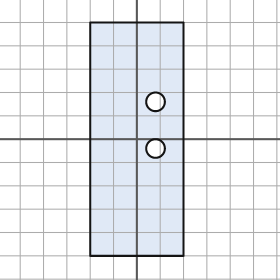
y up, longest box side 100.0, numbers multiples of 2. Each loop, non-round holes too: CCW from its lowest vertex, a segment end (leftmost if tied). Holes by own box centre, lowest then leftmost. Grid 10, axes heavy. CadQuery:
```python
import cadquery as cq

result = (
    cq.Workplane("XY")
    .moveTo(-20.0, -50.0)
    .lineTo(20.0, -50.0)
    .lineTo(20.0, 50.0)
    .lineTo(-20.0, 50.0)
    .close()
    .moveTo(8.0, -4.0)
    .circle(4.0)
    .moveTo(8.0, 16.0)
    .circle(4.0)
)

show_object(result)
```